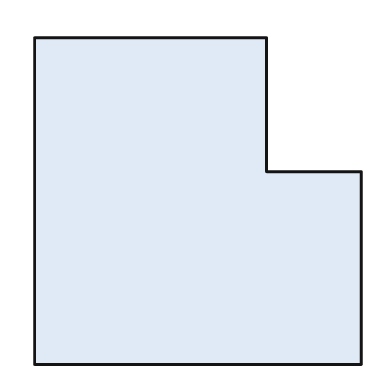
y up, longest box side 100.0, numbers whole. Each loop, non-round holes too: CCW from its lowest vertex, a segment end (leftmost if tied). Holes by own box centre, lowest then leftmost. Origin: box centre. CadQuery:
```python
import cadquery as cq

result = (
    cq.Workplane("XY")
    .moveTo(-50.0, -50.0)
    .lineTo(50.0, -50.0)
    .lineTo(50.0, 9.0)
    .lineTo(21.0, 9.0)
    .lineTo(21.0, 50.0)
    .lineTo(-50.0, 50.0)
    .close()
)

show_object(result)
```